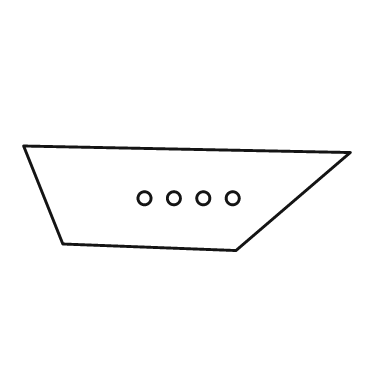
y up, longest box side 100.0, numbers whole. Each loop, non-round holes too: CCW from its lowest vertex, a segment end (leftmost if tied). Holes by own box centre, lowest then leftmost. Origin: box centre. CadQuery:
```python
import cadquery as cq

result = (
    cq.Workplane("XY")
    .moveTo(15.0, -16.0)
    .lineTo(50.0, 14.0)
    .lineTo(-50.0, 16.0)
    .lineTo(-38.0, -14.0)
    .close()
    .moveTo(-13.0, 0.0)
    .circle(2.0)
    .moveTo(-4.0, 0.0)
    .circle(2.0)
    .moveTo(5.0, 0.0)
    .circle(2.0)
    .moveTo(14.0, 0.0)
    .circle(2.0)
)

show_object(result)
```